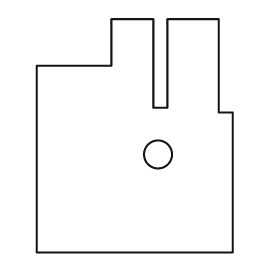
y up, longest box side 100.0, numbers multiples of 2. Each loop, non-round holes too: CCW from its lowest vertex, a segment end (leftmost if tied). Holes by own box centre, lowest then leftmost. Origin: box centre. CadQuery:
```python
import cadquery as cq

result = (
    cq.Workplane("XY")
    .moveTo(-42.0, -50.0)
    .lineTo(42.0, -50.0)
    .lineTo(42.0, 10.0)
    .lineTo(36.0, 10.0)
    .lineTo(36.0, 50.0)
    .lineTo(14.0, 50.0)
    .lineTo(14.0, 12.0)
    .lineTo(8.0, 12.0)
    .lineTo(8.0, 50.0)
    .lineTo(-10.0, 50.0)
    .lineTo(-10.0, 30.0)
    .lineTo(-42.0, 30.0)
    .close()
    .moveTo(10.0, -8.0)
    .circle(6.0)
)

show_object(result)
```